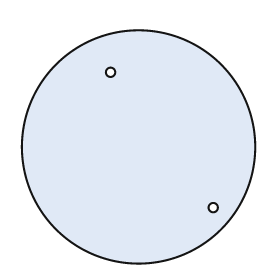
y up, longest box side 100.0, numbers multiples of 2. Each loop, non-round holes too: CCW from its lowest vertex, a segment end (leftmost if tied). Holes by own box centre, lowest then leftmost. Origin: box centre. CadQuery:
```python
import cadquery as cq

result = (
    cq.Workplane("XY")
    .moveTo(0.0, 0.0)
    .circle(50.0)
    .moveTo(32.0, -26.0)
    .circle(2.0)
    .moveTo(-12.0, 32.0)
    .circle(2.0)
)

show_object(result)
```